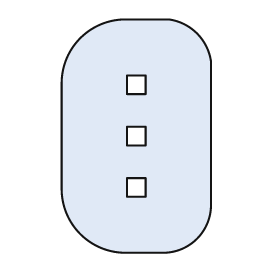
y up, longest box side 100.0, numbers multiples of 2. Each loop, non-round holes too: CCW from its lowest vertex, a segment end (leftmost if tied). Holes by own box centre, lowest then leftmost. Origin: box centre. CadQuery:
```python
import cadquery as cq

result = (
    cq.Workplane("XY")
    .moveTo(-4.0, -50.0)
    .lineTo(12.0, -50.0)
    .threePointArc((26.0, -44.0), (32.0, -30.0))
    .lineTo(32.0, 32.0)
    .threePointArc((26.0, 44.0), (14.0, 50.0))
    .lineTo(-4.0, 50.0)
    .threePointArc((-24.0, 42.0), (-32.0, 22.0))
    .lineTo(-32.0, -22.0)
    .threePointArc((-24.0, -42.0), (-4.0, -50.0))
    .close()
    .moveTo(-4.0, -26.0)
    .lineTo(4.0, -26.0)
    .lineTo(4.0, -18.0)
    .lineTo(-4.0, -18.0)
    .close()
    .moveTo(-4.0, -4.0)
    .lineTo(4.0, -4.0)
    .lineTo(4.0, 4.0)
    .lineTo(-4.0, 4.0)
    .close()
    .moveTo(-4.0, 18.0)
    .lineTo(4.0, 18.0)
    .lineTo(4.0, 26.0)
    .lineTo(-4.0, 26.0)
    .close()
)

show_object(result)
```